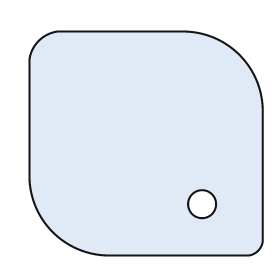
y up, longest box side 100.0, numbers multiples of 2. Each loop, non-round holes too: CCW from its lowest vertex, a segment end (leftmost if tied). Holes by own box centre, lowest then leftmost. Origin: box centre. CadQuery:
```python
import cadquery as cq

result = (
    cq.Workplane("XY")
    .moveTo(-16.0, -48.0)
    .lineTo(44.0, -48.0)
    .threePointArc((48.0, -46.0), (50.0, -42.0))
    .lineTo(50.0, 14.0)
    .threePointArc((40.0, 38.0), (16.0, 48.0))
    .lineTo(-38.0, 48.0)
    .threePointArc((-46.0, 44.0), (-50.0, 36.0))
    .lineTo(-50.0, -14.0)
    .threePointArc((-40.0, -38.0), (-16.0, -48.0))
    .close()
    .moveTo(24.0, -26.0)
    .circle(6.0)
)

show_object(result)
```